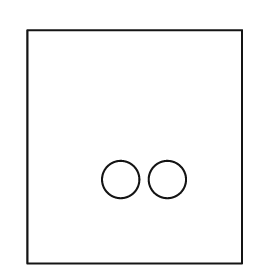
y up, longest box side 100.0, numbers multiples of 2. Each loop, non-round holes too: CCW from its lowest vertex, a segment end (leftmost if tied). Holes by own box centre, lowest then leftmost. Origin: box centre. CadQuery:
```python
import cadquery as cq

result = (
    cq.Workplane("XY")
    .moveTo(-46.0, -50.0)
    .lineTo(46.0, -50.0)
    .lineTo(46.0, 50.0)
    .lineTo(-46.0, 50.0)
    .close()
    .moveTo(-6.0, -14.0)
    .circle(8.0)
    .moveTo(14.0, -14.0)
    .circle(8.0)
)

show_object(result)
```